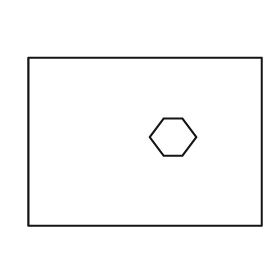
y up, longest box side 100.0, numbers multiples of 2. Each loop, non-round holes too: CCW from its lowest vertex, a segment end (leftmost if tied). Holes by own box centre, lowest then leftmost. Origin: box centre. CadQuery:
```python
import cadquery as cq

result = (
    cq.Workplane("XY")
    .moveTo(-50.0, -36.0)
    .lineTo(50.0, -36.0)
    .lineTo(50.0, 36.0)
    .lineTo(-50.0, 36.0)
    .close()
    .moveTo(8.0, -6.0)
    .lineTo(16.0, -6.0)
    .lineTo(22.0, 2.0)
    .lineTo(16.0, 10.0)
    .lineTo(8.0, 10.0)
    .lineTo(2.0, 2.0)
    .close()
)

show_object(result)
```